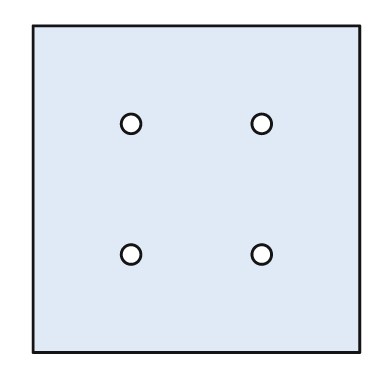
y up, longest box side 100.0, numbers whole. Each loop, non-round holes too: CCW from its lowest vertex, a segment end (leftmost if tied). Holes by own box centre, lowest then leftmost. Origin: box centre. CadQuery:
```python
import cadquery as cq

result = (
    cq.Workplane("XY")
    .moveTo(-50.0, -50.0)
    .lineTo(50.0, -50.0)
    .lineTo(50.0, 50.0)
    .lineTo(-50.0, 50.0)
    .close()
    .moveTo(-20.0, -20.0)
    .circle(3.0)
    .moveTo(20.0, -20.0)
    .circle(3.0)
    .moveTo(-20.0, 20.0)
    .circle(3.0)
    .moveTo(20.0, 20.0)
    .circle(3.0)
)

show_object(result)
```